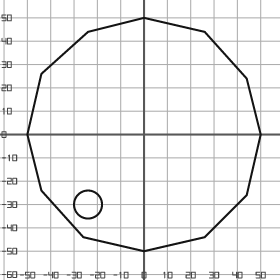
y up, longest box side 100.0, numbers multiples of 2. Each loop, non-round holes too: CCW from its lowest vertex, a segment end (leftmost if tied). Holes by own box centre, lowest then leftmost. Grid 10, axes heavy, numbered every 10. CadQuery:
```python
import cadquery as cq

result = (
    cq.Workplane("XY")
    .moveTo(0.0, -50.0)
    .lineTo(26.0, -44.0)
    .lineTo(44.0, -26.0)
    .lineTo(50.0, 0.0)
    .lineTo(44.0, 24.0)
    .lineTo(26.0, 44.0)
    .lineTo(0.0, 50.0)
    .lineTo(-24.0, 44.0)
    .lineTo(-44.0, 26.0)
    .lineTo(-50.0, 0.0)
    .lineTo(-44.0, -24.0)
    .lineTo(-26.0, -44.0)
    .close()
    .moveTo(-24.0, -30.0)
    .circle(6.0)
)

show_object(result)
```